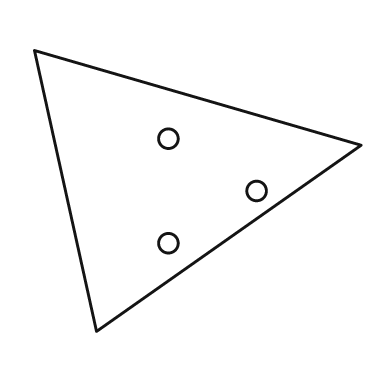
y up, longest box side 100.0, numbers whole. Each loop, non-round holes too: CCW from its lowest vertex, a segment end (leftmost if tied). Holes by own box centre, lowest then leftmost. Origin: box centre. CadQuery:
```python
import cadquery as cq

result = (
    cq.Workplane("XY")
    .moveTo(-31.0, -43.0)
    .lineTo(50.0, 14.0)
    .lineTo(-50.0, 43.0)
    .close()
    .moveTo(-9.0, -16.0)
    .circle(3.0)
    .moveTo(18.0, 0.0)
    .circle(3.0)
    .moveTo(-9.0, 16.0)
    .circle(3.0)
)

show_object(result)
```